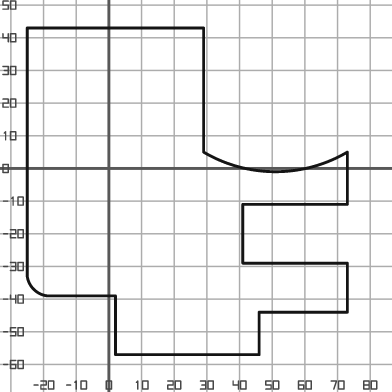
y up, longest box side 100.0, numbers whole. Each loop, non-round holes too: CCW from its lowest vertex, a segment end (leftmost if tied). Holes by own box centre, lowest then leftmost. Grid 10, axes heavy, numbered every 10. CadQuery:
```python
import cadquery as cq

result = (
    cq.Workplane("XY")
    .moveTo(2.0, -57.0)
    .lineTo(46.0, -57.0)
    .lineTo(46.0, -44.0)
    .lineTo(73.0, -44.0)
    .lineTo(73.0, -29.0)
    .lineTo(41.0, -29.0)
    .lineTo(41.0, -11.0)
    .lineTo(73.0, -11.0)
    .lineTo(73.0, 5.0)
    .threePointArc((51.0, -1.0), (29.0, 5.0))
    .lineTo(29.0, 43.0)
    .lineTo(-25.0, 43.0)
    .lineTo(-25.0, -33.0)
    .threePointArc((-23.0, -37.0), (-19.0, -39.0))
    .lineTo(2.0, -39.0)
    .close()
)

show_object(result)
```